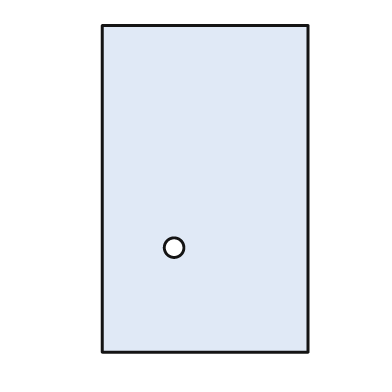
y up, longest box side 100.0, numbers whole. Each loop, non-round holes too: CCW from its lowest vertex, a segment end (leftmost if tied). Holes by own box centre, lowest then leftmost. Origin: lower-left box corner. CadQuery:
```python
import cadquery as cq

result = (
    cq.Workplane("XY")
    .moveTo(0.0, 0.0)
    .lineTo(63.0, 0.0)
    .lineTo(63.0, 100.0)
    .lineTo(0.0, 100.0)
    .close()
    .moveTo(22.0, 32.0)
    .circle(3.0)
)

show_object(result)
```